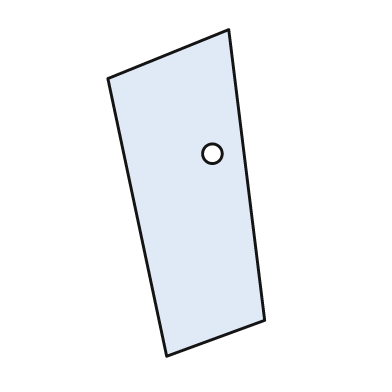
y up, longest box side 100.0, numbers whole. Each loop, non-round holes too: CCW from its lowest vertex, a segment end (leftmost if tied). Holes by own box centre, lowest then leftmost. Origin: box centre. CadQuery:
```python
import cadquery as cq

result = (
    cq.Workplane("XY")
    .moveTo(-6.0, -50.0)
    .lineTo(24.0, -39.0)
    .lineTo(13.0, 50.0)
    .lineTo(-24.0, 35.0)
    .close()
    .moveTo(8.0, 12.0)
    .circle(3.0)
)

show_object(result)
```